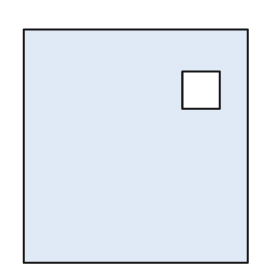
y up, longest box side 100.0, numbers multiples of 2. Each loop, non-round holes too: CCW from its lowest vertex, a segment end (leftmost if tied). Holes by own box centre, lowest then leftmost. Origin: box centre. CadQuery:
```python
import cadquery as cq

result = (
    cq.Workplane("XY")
    .moveTo(-48.0, -50.0)
    .lineTo(48.0, -50.0)
    .lineTo(48.0, 50.0)
    .lineTo(-48.0, 50.0)
    .close()
    .moveTo(20.0, 16.0)
    .lineTo(36.0, 16.0)
    .lineTo(36.0, 32.0)
    .lineTo(20.0, 32.0)
    .close()
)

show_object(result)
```